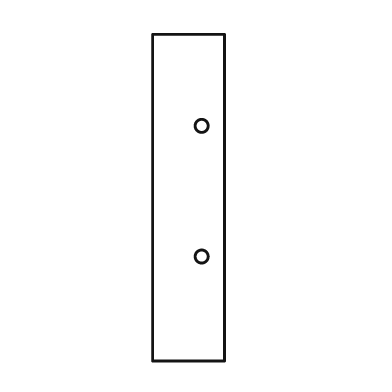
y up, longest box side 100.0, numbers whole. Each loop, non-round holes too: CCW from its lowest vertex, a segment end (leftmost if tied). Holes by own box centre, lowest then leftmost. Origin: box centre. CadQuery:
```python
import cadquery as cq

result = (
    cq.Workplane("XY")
    .moveTo(-11.0, -50.0)
    .lineTo(11.0, -50.0)
    .lineTo(11.0, 50.0)
    .lineTo(-11.0, 50.0)
    .close()
    .moveTo(4.0, -18.0)
    .circle(2.0)
    .moveTo(4.0, 22.0)
    .circle(2.0)
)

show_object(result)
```